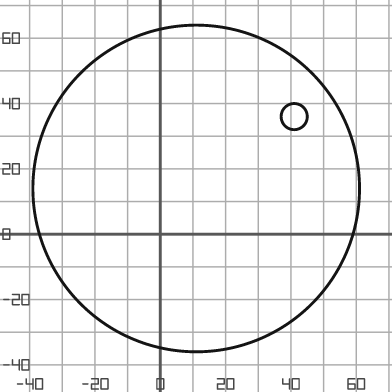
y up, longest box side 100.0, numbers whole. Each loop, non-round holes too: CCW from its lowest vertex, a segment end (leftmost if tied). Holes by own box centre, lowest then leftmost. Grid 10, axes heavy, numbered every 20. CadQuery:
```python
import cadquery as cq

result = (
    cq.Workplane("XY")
    .moveTo(11.0, 14.0)
    .circle(50.0)
    .moveTo(41.0, 36.0)
    .circle(4.0)
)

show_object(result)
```